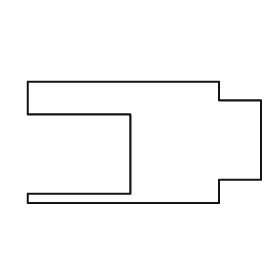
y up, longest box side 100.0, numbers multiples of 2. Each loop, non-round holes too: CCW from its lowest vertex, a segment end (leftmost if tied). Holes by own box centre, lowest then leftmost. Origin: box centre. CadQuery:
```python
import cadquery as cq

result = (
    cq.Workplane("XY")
    .moveTo(-50.0, -26.0)
    .lineTo(32.0, -26.0)
    .lineTo(32.0, -16.0)
    .lineTo(50.0, -16.0)
    .lineTo(50.0, 18.0)
    .lineTo(32.0, 18.0)
    .lineTo(32.0, 26.0)
    .lineTo(-50.0, 26.0)
    .lineTo(-50.0, 12.0)
    .lineTo(-6.0, 12.0)
    .lineTo(-6.0, -22.0)
    .lineTo(-50.0, -22.0)
    .close()
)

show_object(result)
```